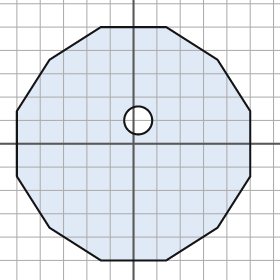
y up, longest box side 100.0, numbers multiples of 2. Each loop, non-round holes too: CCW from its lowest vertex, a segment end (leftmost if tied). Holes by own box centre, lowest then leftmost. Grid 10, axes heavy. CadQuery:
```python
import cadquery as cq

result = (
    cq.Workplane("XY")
    .moveTo(-14.0, -50.0)
    .lineTo(14.0, -50.0)
    .lineTo(36.0, -36.0)
    .lineTo(50.0, -14.0)
    .lineTo(50.0, 14.0)
    .lineTo(36.0, 36.0)
    .lineTo(14.0, 50.0)
    .lineTo(-14.0, 50.0)
    .lineTo(-36.0, 36.0)
    .lineTo(-50.0, 14.0)
    .lineTo(-50.0, -14.0)
    .lineTo(-36.0, -36.0)
    .close()
    .moveTo(2.0, 10.0)
    .circle(6.0)
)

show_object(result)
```